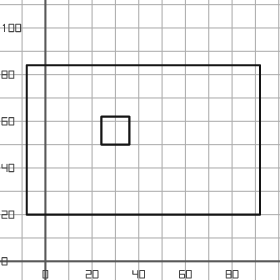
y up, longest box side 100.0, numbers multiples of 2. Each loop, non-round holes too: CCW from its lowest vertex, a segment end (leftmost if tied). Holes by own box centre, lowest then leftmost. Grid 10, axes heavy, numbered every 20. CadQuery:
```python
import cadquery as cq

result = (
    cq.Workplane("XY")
    .moveTo(-8.0, 20.0)
    .lineTo(92.0, 20.0)
    .lineTo(92.0, 84.0)
    .lineTo(-8.0, 84.0)
    .close()
    .moveTo(24.0, 50.0)
    .lineTo(36.0, 50.0)
    .lineTo(36.0, 62.0)
    .lineTo(24.0, 62.0)
    .close()
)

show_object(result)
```